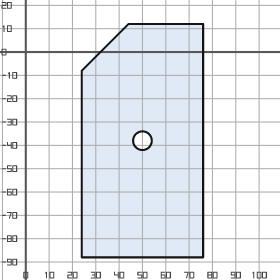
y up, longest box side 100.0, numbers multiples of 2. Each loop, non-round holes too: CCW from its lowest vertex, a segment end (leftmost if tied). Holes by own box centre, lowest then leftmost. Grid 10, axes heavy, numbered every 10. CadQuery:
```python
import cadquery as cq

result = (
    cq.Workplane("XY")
    .moveTo(24.0, -88.0)
    .lineTo(76.0, -88.0)
    .lineTo(76.0, 12.0)
    .lineTo(44.0, 12.0)
    .lineTo(24.0, -8.0)
    .close()
    .moveTo(50.0, -38.0)
    .circle(4.0)
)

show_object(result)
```